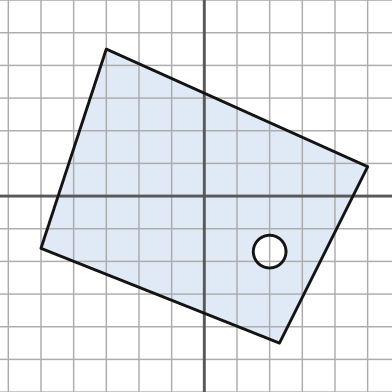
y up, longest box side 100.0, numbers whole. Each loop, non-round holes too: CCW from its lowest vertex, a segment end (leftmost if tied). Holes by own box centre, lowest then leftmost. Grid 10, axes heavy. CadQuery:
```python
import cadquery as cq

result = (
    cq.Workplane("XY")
    .moveTo(23.0, -45.0)
    .lineTo(50.0, 9.0)
    .lineTo(-30.0, 45.0)
    .lineTo(-50.0, -16.0)
    .close()
    .moveTo(20.0, -17.0)
    .circle(5.0)
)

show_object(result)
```